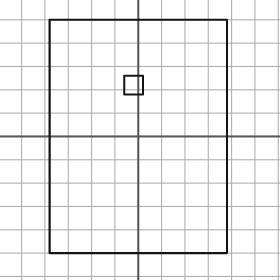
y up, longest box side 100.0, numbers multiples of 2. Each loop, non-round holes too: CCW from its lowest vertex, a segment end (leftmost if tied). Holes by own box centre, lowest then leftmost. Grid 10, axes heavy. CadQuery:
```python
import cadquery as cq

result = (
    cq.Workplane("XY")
    .moveTo(-38.0, -50.0)
    .lineTo(38.0, -50.0)
    .lineTo(38.0, 50.0)
    .lineTo(-38.0, 50.0)
    .close()
    .moveTo(-6.0, 18.0)
    .lineTo(2.0, 18.0)
    .lineTo(2.0, 26.0)
    .lineTo(-6.0, 26.0)
    .close()
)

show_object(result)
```